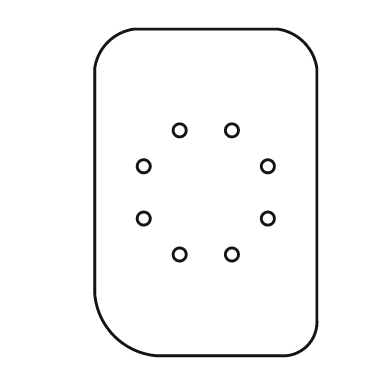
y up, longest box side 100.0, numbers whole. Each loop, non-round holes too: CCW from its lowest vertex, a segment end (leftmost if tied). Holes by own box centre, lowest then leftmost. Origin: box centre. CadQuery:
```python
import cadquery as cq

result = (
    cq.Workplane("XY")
    .moveTo(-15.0, -50.0)
    .lineTo(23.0, -50.0)
    .threePointArc((31.0, -47.0), (34.0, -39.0))
    .lineTo(34.0, 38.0)
    .threePointArc((30.0, 46.0), (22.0, 50.0))
    .lineTo(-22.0, 50.0)
    .threePointArc((-30.0, 46.0), (-34.0, 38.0))
    .lineTo(-34.0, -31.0)
    .threePointArc((-28.0, -44.0), (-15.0, -50.0))
    .close()
    .moveTo(-8.0, -19.0)
    .circle(2.0)
    .moveTo(8.0, -19.0)
    .circle(2.0)
    .moveTo(-19.0, -8.0)
    .circle(2.0)
    .moveTo(19.0, -8.0)
    .circle(2.0)
    .moveTo(-19.0, 8.0)
    .circle(2.0)
    .moveTo(19.0, 8.0)
    .circle(2.0)
    .moveTo(-8.0, 19.0)
    .circle(2.0)
    .moveTo(8.0, 19.0)
    .circle(2.0)
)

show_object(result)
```